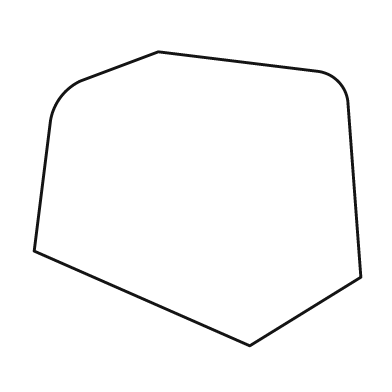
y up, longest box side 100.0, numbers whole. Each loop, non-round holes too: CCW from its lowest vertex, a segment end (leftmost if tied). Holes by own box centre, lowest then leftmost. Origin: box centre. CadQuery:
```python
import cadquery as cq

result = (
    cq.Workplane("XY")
    .moveTo(16.0, -45.0)
    .lineTo(50.0, -24.0)
    .lineTo(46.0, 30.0)
    .threePointArc((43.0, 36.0), (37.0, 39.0))
    .lineTo(-12.0, 45.0)
    .lineTo(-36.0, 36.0)
    .threePointArc((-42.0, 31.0), (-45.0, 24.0))
    .lineTo(-50.0, -16.0)
    .close()
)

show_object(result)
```